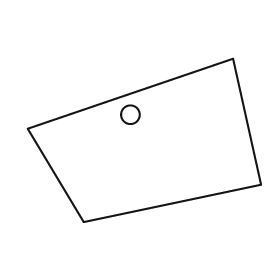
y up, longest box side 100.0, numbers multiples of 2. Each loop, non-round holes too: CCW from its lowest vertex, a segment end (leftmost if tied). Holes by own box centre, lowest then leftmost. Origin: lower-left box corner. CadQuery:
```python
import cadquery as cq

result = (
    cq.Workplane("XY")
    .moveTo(24.0, 0.0)
    .lineTo(100.0, 16.0)
    .lineTo(88.0, 70.0)
    .lineTo(0.0, 40.0)
    .close()
    .moveTo(44.0, 46.0)
    .circle(4.0)
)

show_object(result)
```